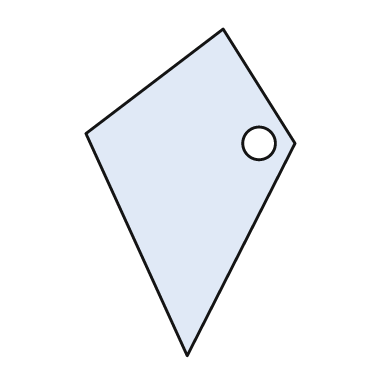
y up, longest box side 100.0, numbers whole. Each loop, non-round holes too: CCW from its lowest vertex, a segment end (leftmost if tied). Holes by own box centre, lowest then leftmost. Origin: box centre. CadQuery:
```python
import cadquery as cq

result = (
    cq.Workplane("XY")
    .moveTo(-1.0, -50.0)
    .lineTo(32.0, 15.0)
    .lineTo(10.0, 50.0)
    .lineTo(-32.0, 18.0)
    .close()
    .moveTo(21.0, 15.0)
    .circle(5.0)
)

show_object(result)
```